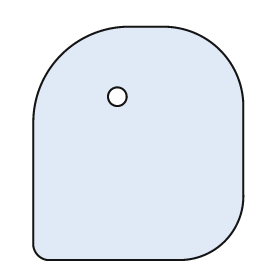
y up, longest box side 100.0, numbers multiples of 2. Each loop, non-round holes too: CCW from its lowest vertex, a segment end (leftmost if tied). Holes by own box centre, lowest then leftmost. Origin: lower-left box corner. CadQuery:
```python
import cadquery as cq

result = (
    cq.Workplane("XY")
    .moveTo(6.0, 0.0)
    .lineTo(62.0, 0.0)
    .threePointArc((82.0, 8.0), (90.0, 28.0))
    .lineTo(90.0, 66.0)
    .threePointArc((80.0, 90.0), (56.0, 100.0))
    .lineTo(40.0, 100.0)
    .threePointArc((12.0, 88.0), (0.0, 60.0))
    .lineTo(0.0, 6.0)
    .threePointArc((2.0, 2.0), (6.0, 0.0))
    .close()
    .moveTo(36.0, 70.0)
    .circle(4.0)
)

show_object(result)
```